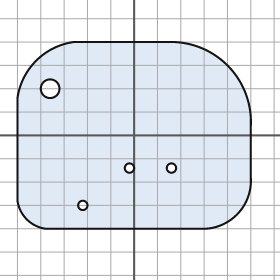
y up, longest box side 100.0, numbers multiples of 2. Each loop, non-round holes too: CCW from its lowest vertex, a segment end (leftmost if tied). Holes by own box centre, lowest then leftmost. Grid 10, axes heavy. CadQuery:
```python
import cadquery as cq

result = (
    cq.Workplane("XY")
    .moveTo(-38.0, -40.0)
    .lineTo(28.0, -40.0)
    .threePointArc((44.0, -34.0), (50.0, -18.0))
    .lineTo(50.0, 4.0)
    .threePointArc((40.0, 30.0), (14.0, 40.0))
    .lineTo(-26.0, 40.0)
    .threePointArc((-42.0, 32.0), (-50.0, 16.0))
    .lineTo(-50.0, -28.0)
    .threePointArc((-46.0, -36.0), (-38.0, -40.0))
    .close()
    .moveTo(-22.0, -30.0)
    .circle(2.0)
    .moveTo(-2.0, -14.0)
    .circle(2.0)
    .moveTo(16.0, -14.0)
    .circle(2.0)
    .moveTo(-36.0, 20.0)
    .circle(4.0)
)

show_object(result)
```